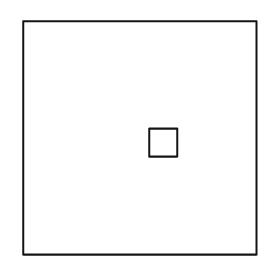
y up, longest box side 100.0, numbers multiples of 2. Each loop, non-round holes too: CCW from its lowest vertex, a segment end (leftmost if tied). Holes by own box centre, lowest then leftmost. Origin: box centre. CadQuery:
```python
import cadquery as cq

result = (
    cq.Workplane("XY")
    .moveTo(-50.0, -50.0)
    .lineTo(50.0, -50.0)
    .lineTo(50.0, 50.0)
    .lineTo(-50.0, 50.0)
    .close()
    .moveTo(4.0, -8.0)
    .lineTo(16.0, -8.0)
    .lineTo(16.0, 4.0)
    .lineTo(4.0, 4.0)
    .close()
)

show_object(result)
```